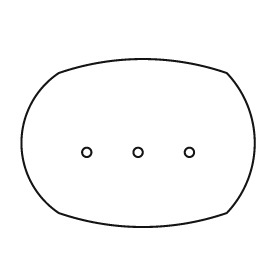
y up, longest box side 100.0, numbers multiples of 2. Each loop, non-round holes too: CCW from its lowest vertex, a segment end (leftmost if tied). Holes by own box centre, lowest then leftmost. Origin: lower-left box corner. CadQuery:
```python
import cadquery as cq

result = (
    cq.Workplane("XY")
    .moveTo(16.0, 6.0)
    .threePointArc((52.0, 0.0), (88.0, 6.0))
    .threePointArc((100.0, 36.0), (88.0, 66.0))
    .threePointArc((52.0, 72.0), (16.0, 66.0))
    .threePointArc((0.0, 36.0), (16.0, 6.0))
    .close()
    .moveTo(28.0, 32.0)
    .circle(2.0)
    .moveTo(50.0, 32.0)
    .circle(2.0)
    .moveTo(72.0, 32.0)
    .circle(2.0)
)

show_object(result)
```